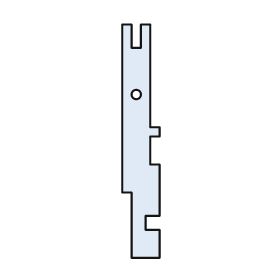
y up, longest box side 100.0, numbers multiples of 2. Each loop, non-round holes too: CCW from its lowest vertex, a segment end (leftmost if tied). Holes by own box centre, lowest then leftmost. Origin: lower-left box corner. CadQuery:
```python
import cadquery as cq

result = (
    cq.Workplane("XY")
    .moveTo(4.0, 0.0)
    .lineTo(16.0, 0.0)
    .lineTo(16.0, 12.0)
    .lineTo(10.0, 12.0)
    .lineTo(10.0, 18.0)
    .lineTo(16.0, 18.0)
    .lineTo(16.0, 40.0)
    .lineTo(12.0, 40.0)
    .lineTo(12.0, 52.0)
    .lineTo(16.0, 52.0)
    .lineTo(16.0, 56.0)
    .lineTo(12.0, 56.0)
    .lineTo(12.0, 100.0)
    .lineTo(8.0, 100.0)
    .lineTo(8.0, 90.0)
    .lineTo(4.0, 90.0)
    .lineTo(4.0, 100.0)
    .lineTo(0.0, 100.0)
    .lineTo(0.0, 28.0)
    .lineTo(4.0, 28.0)
    .close()
    .moveTo(6.0, 70.0)
    .circle(2.0)
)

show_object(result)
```